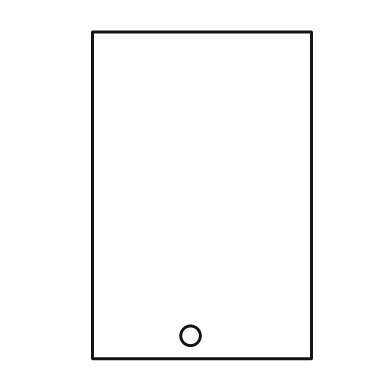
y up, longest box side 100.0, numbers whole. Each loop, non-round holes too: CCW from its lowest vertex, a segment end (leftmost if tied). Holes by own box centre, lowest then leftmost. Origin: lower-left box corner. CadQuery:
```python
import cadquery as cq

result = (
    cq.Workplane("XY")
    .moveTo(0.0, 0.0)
    .lineTo(67.0, 0.0)
    .lineTo(67.0, 100.0)
    .lineTo(0.0, 100.0)
    .close()
    .moveTo(30.0, 7.0)
    .circle(3.0)
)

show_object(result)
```